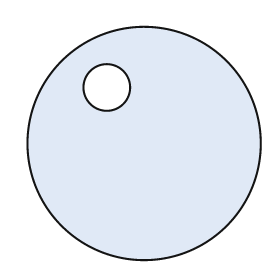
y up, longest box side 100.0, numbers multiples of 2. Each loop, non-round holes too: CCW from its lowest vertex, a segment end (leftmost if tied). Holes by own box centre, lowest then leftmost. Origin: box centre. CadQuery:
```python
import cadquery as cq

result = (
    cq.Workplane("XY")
    .moveTo(0.0, 0.0)
    .circle(50.0)
    .moveTo(-16.0, 24.0)
    .circle(10.0)
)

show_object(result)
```